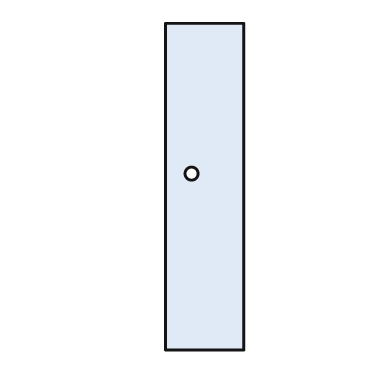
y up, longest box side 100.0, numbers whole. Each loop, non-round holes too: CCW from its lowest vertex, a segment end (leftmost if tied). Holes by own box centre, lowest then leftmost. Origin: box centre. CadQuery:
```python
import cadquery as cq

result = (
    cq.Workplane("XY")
    .moveTo(-12.0, -50.0)
    .lineTo(12.0, -50.0)
    .lineTo(12.0, 50.0)
    .lineTo(-12.0, 50.0)
    .close()
    .moveTo(-4.0, 4.0)
    .circle(2.0)
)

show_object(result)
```